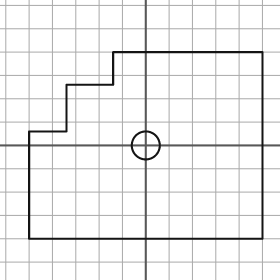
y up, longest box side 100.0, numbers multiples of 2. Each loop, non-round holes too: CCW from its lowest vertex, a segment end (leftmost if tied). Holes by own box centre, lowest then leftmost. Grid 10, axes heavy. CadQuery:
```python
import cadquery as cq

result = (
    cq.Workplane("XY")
    .moveTo(-50.0, -40.0)
    .lineTo(50.0, -40.0)
    .lineTo(50.0, 40.0)
    .lineTo(-14.0, 40.0)
    .lineTo(-14.0, 26.0)
    .lineTo(-34.0, 26.0)
    .lineTo(-34.0, 6.0)
    .lineTo(-50.0, 6.0)
    .close()
    .moveTo(0.0, 0.0)
    .circle(6.0)
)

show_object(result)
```